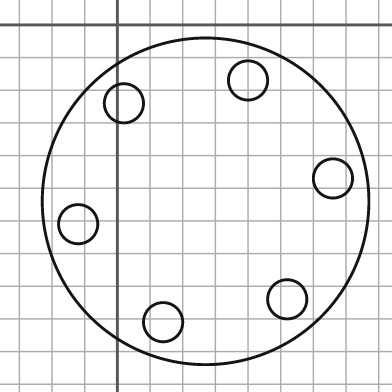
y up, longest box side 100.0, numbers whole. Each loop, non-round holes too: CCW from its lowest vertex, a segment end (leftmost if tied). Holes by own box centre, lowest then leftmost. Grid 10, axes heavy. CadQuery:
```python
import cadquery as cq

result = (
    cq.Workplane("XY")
    .moveTo(27.0, -54.0)
    .circle(50.0)
    .moveTo(14.0, -91.0)
    .circle(6.0)
    .moveTo(52.0, -84.0)
    .circle(6.0)
    .moveTo(-12.0, -61.0)
    .circle(6.0)
    .moveTo(66.0, -47.0)
    .circle(6.0)
    .moveTo(2.0, -24.0)
    .circle(6.0)
    .moveTo(40.0, -17.0)
    .circle(6.0)
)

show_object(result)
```